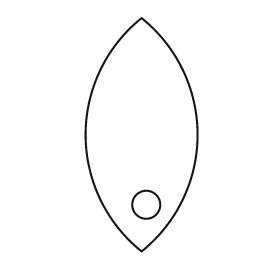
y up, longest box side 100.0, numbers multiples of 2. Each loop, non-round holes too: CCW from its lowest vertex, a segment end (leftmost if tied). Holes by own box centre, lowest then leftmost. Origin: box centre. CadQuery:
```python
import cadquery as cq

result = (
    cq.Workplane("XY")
    .moveTo(0.0, -50.0)
    .threePointArc((24.0, 0.0), (0.0, 50.0))
    .threePointArc((-24.0, 0.0), (0.0, -50.0))
    .close()
    .moveTo(2.0, -30.0)
    .circle(6.0)
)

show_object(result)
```